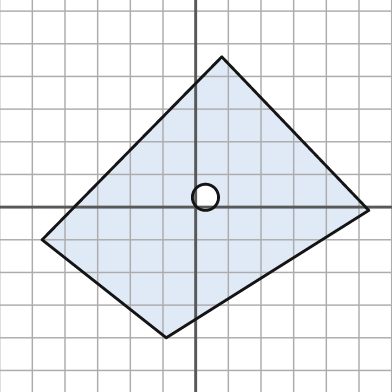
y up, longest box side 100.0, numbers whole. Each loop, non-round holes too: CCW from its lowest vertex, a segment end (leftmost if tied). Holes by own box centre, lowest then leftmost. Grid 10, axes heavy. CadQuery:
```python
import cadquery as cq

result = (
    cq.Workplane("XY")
    .moveTo(-9.0, -40.0)
    .lineTo(53.0, -1.0)
    .lineTo(8.0, 46.0)
    .lineTo(-47.0, -10.0)
    .close()
    .moveTo(3.0, 3.0)
    .circle(4.0)
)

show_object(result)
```